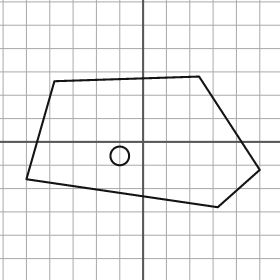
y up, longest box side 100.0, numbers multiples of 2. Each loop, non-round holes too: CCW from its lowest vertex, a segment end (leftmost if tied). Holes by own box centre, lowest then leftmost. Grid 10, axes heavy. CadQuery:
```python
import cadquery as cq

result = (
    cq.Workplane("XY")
    .moveTo(32.0, -28.0)
    .lineTo(50.0, -12.0)
    .lineTo(24.0, 28.0)
    .lineTo(-38.0, 26.0)
    .lineTo(-50.0, -16.0)
    .close()
    .moveTo(-10.0, -6.0)
    .circle(4.0)
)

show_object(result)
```